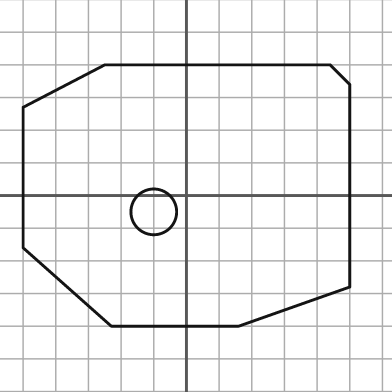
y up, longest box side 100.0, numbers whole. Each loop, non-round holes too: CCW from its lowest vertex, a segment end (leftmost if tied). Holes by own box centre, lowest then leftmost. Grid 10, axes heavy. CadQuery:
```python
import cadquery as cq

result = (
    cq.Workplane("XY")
    .moveTo(-23.0, -40.0)
    .lineTo(16.0, -40.0)
    .lineTo(50.0, -28.0)
    .lineTo(50.0, 34.0)
    .lineTo(44.0, 40.0)
    .lineTo(-25.0, 40.0)
    .lineTo(-50.0, 27.0)
    .lineTo(-50.0, -16.0)
    .close()
    .moveTo(-10.0, -5.0)
    .circle(7.0)
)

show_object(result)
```